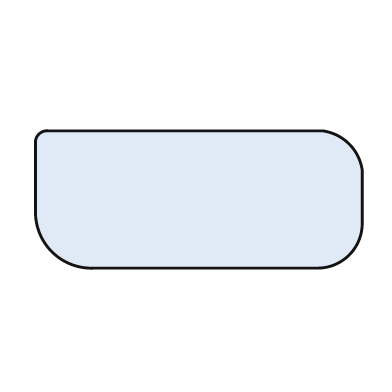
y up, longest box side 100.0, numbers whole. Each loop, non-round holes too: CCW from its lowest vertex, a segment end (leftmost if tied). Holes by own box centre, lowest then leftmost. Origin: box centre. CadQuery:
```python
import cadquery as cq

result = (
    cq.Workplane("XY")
    .moveTo(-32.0, -21.0)
    .lineTo(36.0, -21.0)
    .threePointArc((46.0, -17.0), (50.0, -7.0))
    .lineTo(50.0, 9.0)
    .threePointArc((46.0, 17.0), (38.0, 21.0))
    .lineTo(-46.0, 21.0)
    .threePointArc((-49.0, 20.0), (-50.0, 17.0))
    .lineTo(-50.0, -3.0)
    .threePointArc((-45.0, -16.0), (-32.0, -21.0))
    .close()
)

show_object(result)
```